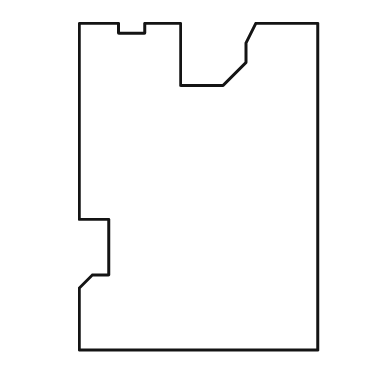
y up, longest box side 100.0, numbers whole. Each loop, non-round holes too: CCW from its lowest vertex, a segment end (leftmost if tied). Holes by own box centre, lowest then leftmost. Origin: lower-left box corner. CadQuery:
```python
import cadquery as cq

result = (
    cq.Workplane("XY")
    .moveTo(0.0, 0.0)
    .lineTo(73.0, 0.0)
    .lineTo(73.0, 100.0)
    .lineTo(54.0, 100.0)
    .lineTo(51.0, 94.0)
    .lineTo(51.0, 88.0)
    .lineTo(44.0, 81.0)
    .lineTo(31.0, 81.0)
    .lineTo(31.0, 100.0)
    .lineTo(20.0, 100.0)
    .lineTo(20.0, 97.0)
    .lineTo(12.0, 97.0)
    .lineTo(12.0, 100.0)
    .lineTo(0.0, 100.0)
    .lineTo(0.0, 40.0)
    .lineTo(9.0, 40.0)
    .lineTo(9.0, 23.0)
    .lineTo(4.0, 23.0)
    .lineTo(0.0, 19.0)
    .close()
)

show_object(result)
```